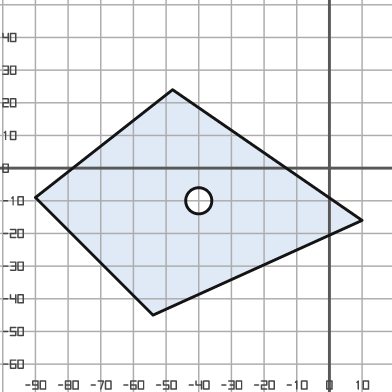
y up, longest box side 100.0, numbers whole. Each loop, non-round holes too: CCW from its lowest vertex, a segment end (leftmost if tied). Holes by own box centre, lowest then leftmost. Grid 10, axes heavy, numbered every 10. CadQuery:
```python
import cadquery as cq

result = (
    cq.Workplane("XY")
    .moveTo(-54.0, -45.0)
    .lineTo(10.0, -16.0)
    .lineTo(-48.0, 24.0)
    .lineTo(-90.0, -9.0)
    .close()
    .moveTo(-40.0, -10.0)
    .circle(4.0)
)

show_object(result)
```